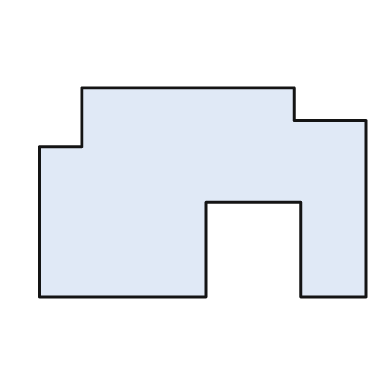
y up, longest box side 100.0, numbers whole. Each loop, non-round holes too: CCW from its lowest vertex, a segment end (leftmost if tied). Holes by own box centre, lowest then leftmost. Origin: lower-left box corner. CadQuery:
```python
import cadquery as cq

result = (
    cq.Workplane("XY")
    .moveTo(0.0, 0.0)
    .lineTo(51.0, 0.0)
    .lineTo(51.0, 29.0)
    .lineTo(80.0, 29.0)
    .lineTo(80.0, 0.0)
    .lineTo(100.0, 0.0)
    .lineTo(100.0, 54.0)
    .lineTo(78.0, 54.0)
    .lineTo(78.0, 64.0)
    .lineTo(13.0, 64.0)
    .lineTo(13.0, 46.0)
    .lineTo(0.0, 46.0)
    .close()
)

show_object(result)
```